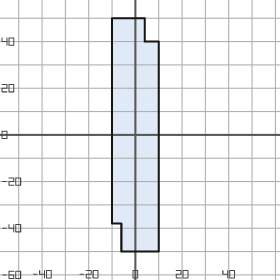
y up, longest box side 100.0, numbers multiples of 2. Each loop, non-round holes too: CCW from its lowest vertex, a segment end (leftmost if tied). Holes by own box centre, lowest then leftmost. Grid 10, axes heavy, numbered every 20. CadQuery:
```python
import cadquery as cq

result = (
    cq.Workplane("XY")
    .moveTo(-6.0, -50.0)
    .lineTo(10.0, -50.0)
    .lineTo(10.0, 40.0)
    .lineTo(4.0, 40.0)
    .lineTo(4.0, 50.0)
    .lineTo(-10.0, 50.0)
    .lineTo(-10.0, -38.0)
    .lineTo(-6.0, -38.0)
    .close()
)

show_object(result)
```